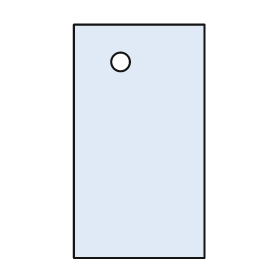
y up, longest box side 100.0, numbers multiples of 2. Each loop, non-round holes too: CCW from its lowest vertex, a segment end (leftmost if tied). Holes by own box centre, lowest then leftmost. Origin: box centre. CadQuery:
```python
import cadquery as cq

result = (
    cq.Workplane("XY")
    .moveTo(-28.0, -50.0)
    .lineTo(28.0, -50.0)
    .lineTo(28.0, 50.0)
    .lineTo(-28.0, 50.0)
    .close()
    .moveTo(-8.0, 34.0)
    .circle(4.0)
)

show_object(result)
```